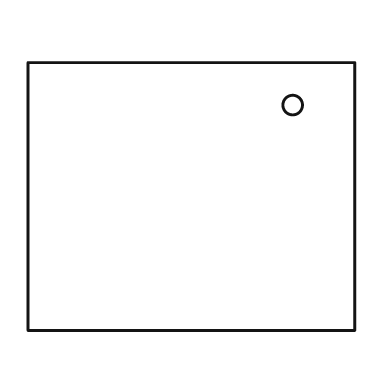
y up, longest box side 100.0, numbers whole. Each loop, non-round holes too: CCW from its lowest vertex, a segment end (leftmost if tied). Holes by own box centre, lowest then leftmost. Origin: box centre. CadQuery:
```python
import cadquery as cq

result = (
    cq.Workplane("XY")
    .moveTo(-50.0, -41.0)
    .lineTo(50.0, -41.0)
    .lineTo(50.0, 41.0)
    .lineTo(-50.0, 41.0)
    .close()
    .moveTo(31.0, 28.0)
    .circle(3.0)
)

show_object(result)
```